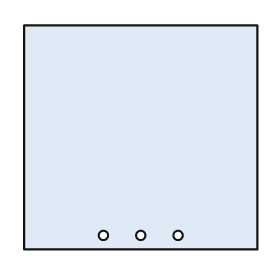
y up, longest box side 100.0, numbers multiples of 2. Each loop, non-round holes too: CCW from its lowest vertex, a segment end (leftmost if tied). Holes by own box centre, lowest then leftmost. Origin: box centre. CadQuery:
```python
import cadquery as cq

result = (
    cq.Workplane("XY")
    .moveTo(-50.0, -48.0)
    .lineTo(50.0, -48.0)
    .lineTo(50.0, 48.0)
    .lineTo(-50.0, 48.0)
    .close()
    .moveTo(-16.0, -42.0)
    .circle(2.0)
    .moveTo(0.0, -42.0)
    .circle(2.0)
    .moveTo(16.0, -42.0)
    .circle(2.0)
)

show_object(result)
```